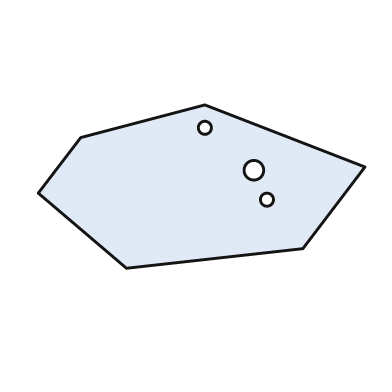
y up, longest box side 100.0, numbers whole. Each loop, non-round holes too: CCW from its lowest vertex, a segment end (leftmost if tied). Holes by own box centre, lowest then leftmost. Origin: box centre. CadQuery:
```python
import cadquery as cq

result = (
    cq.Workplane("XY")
    .moveTo(-23.0, -25.0)
    .lineTo(31.0, -19.0)
    .lineTo(50.0, 6.0)
    .lineTo(1.0, 25.0)
    .lineTo(-37.0, 15.0)
    .lineTo(-50.0, -2.0)
    .close()
    .moveTo(20.0, -4.0)
    .circle(2.0)
    .moveTo(16.0, 5.0)
    .circle(3.0)
    .moveTo(1.0, 18.0)
    .circle(2.0)
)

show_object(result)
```